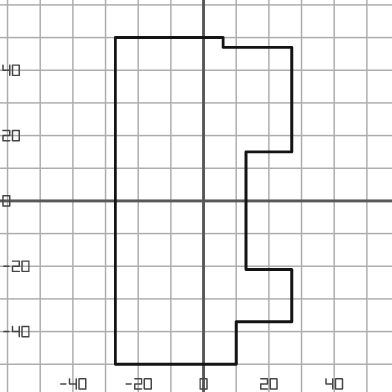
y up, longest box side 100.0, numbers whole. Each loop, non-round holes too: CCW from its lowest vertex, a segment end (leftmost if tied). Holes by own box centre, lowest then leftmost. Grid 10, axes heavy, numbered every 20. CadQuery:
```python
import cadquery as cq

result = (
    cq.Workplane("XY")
    .moveTo(-27.0, -50.0)
    .lineTo(10.0, -50.0)
    .lineTo(10.0, -37.0)
    .lineTo(27.0, -37.0)
    .lineTo(27.0, -21.0)
    .lineTo(13.0, -21.0)
    .lineTo(13.0, 15.0)
    .lineTo(27.0, 15.0)
    .lineTo(27.0, 47.0)
    .lineTo(6.0, 47.0)
    .lineTo(6.0, 50.0)
    .lineTo(-27.0, 50.0)
    .close()
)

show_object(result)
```